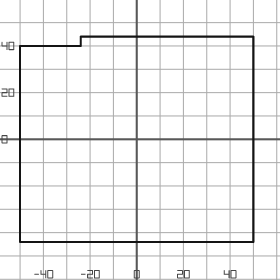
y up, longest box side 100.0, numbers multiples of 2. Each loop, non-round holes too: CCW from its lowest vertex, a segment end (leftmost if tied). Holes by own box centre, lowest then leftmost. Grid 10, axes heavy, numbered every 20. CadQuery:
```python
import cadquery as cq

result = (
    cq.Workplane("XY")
    .moveTo(-50.0, -44.0)
    .lineTo(50.0, -44.0)
    .lineTo(50.0, 44.0)
    .lineTo(-24.0, 44.0)
    .lineTo(-24.0, 40.0)
    .lineTo(-50.0, 40.0)
    .close()
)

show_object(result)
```